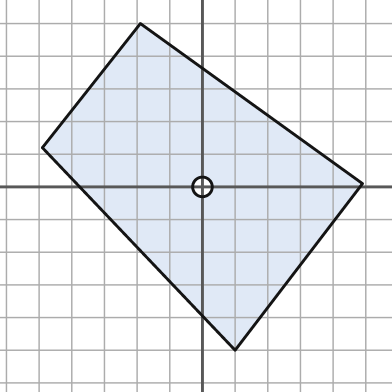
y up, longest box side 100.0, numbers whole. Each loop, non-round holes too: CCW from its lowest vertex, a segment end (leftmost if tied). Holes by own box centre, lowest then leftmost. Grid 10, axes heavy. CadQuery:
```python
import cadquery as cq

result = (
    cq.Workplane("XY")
    .moveTo(10.0, -50.0)
    .lineTo(49.0, 1.0)
    .lineTo(-19.0, 50.0)
    .lineTo(-49.0, 12.0)
    .close()
    .moveTo(0.0, 0.0)
    .circle(3.0)
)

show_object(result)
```